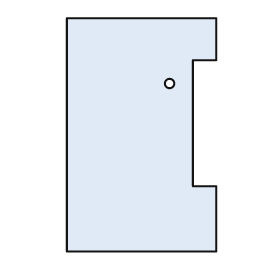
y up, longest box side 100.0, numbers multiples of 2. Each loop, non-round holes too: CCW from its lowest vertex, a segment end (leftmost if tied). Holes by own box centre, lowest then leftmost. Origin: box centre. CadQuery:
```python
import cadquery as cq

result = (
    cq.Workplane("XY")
    .moveTo(-32.0, -50.0)
    .lineTo(32.0, -50.0)
    .lineTo(32.0, -22.0)
    .lineTo(22.0, -22.0)
    .lineTo(22.0, 32.0)
    .lineTo(32.0, 32.0)
    .lineTo(32.0, 50.0)
    .lineTo(-32.0, 50.0)
    .close()
    .moveTo(12.0, 22.0)
    .circle(2.0)
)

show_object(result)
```